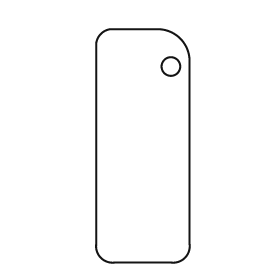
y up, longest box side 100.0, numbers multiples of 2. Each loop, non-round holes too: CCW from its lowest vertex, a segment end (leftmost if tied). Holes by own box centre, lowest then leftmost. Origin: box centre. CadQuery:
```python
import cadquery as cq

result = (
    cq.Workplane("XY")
    .moveTo(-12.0, -50.0)
    .lineTo(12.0, -50.0)
    .threePointArc((18.0, -48.0), (20.0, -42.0))
    .lineTo(20.0, 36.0)
    .threePointArc((16.0, 46.0), (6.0, 50.0))
    .lineTo(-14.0, 50.0)
    .threePointArc((-18.0, 48.0), (-20.0, 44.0))
    .lineTo(-20.0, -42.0)
    .threePointArc((-18.0, -48.0), (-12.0, -50.0))
    .close()
    .moveTo(12.0, 34.0)
    .circle(4.0)
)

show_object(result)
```